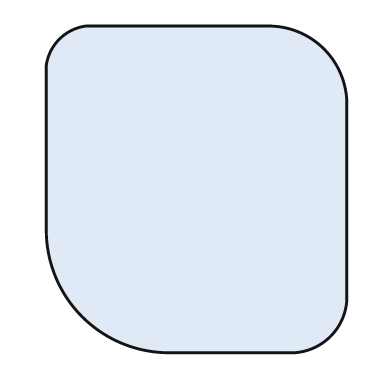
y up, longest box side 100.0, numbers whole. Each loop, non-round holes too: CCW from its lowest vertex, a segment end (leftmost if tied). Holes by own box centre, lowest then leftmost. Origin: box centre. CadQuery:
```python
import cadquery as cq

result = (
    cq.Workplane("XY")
    .moveTo(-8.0, -50.0)
    .lineTo(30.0, -50.0)
    .threePointArc((41.0, -45.0), (46.0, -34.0))
    .lineTo(46.0, 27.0)
    .threePointArc((39.0, 43.0), (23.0, 50.0))
    .lineTo(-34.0, 50.0)
    .threePointArc((-42.0, 46.0), (-46.0, 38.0))
    .lineTo(-46.0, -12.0)
    .threePointArc((-35.0, -39.0), (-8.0, -50.0))
    .close()
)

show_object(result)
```